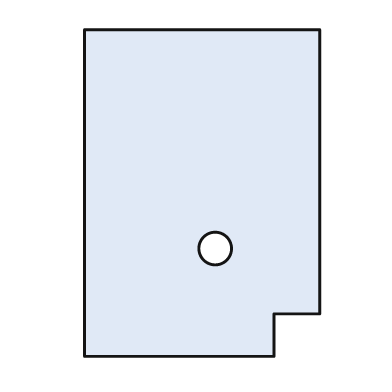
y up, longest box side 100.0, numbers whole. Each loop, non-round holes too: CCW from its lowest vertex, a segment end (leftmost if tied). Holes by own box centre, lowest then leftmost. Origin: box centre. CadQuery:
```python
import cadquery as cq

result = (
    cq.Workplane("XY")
    .moveTo(-36.0, -50.0)
    .lineTo(22.0, -50.0)
    .lineTo(22.0, -37.0)
    .lineTo(36.0, -37.0)
    .lineTo(36.0, 50.0)
    .lineTo(-36.0, 50.0)
    .close()
    .moveTo(4.0, -17.0)
    .circle(5.0)
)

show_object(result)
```